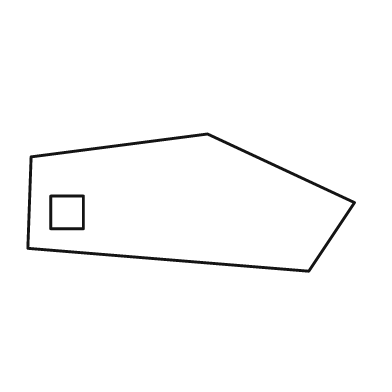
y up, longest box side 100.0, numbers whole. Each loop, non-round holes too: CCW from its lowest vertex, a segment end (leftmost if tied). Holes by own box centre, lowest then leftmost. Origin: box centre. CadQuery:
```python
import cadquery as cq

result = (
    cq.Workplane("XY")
    .moveTo(36.0, -21.0)
    .lineTo(50.0, 0.0)
    .lineTo(5.0, 21.0)
    .lineTo(-49.0, 14.0)
    .lineTo(-50.0, -14.0)
    .close()
    .moveTo(-43.0, -8.0)
    .lineTo(-33.0, -8.0)
    .lineTo(-33.0, 2.0)
    .lineTo(-43.0, 2.0)
    .close()
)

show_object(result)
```